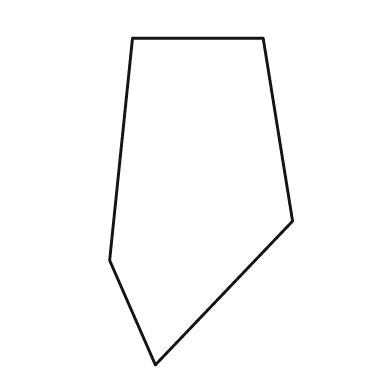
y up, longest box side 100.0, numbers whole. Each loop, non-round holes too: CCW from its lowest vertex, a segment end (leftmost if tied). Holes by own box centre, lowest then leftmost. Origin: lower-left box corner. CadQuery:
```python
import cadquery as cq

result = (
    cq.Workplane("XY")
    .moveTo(14.0, 0.0)
    .lineTo(56.0, 44.0)
    .lineTo(47.0, 100.0)
    .lineTo(7.0, 100.0)
    .lineTo(0.0, 32.0)
    .close()
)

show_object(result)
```